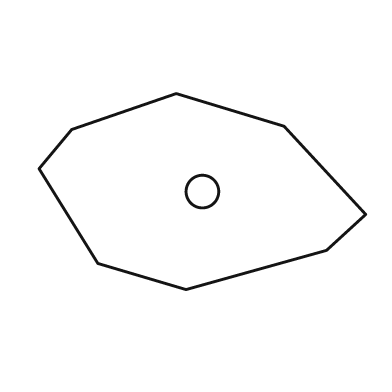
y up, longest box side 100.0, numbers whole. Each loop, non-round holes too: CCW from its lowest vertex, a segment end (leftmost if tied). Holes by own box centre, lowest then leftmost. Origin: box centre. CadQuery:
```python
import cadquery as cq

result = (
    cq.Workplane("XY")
    .moveTo(-5.0, -30.0)
    .lineTo(38.0, -18.0)
    .lineTo(50.0, -7.0)
    .lineTo(25.0, 20.0)
    .lineTo(-8.0, 30.0)
    .lineTo(-40.0, 19.0)
    .lineTo(-50.0, 7.0)
    .lineTo(-32.0, -22.0)
    .close()
    .moveTo(0.0, 0.0)
    .circle(5.0)
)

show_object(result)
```